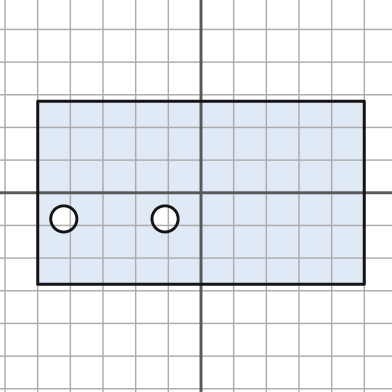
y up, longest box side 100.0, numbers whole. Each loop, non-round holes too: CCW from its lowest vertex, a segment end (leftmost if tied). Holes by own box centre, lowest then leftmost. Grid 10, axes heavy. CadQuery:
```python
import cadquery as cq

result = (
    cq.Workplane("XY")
    .moveTo(-50.0, -28.0)
    .lineTo(50.0, -28.0)
    .lineTo(50.0, 28.0)
    .lineTo(-50.0, 28.0)
    .close()
    .moveTo(-42.0, -8.0)
    .circle(4.0)
    .moveTo(-11.0, -8.0)
    .circle(4.0)
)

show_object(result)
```